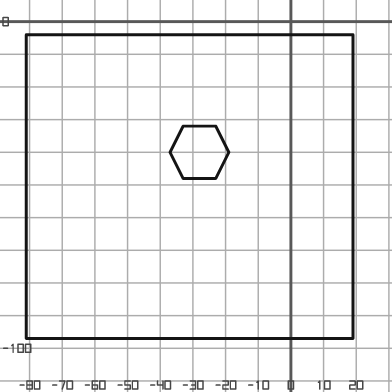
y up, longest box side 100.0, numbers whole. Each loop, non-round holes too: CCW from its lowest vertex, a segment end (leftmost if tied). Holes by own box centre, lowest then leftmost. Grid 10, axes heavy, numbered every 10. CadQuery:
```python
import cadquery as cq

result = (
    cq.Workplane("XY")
    .moveTo(-81.0, -97.0)
    .lineTo(19.0, -97.0)
    .lineTo(19.0, -4.0)
    .lineTo(-81.0, -4.0)
    .close()
    .moveTo(-33.0, -48.0)
    .lineTo(-23.0, -48.0)
    .lineTo(-19.0, -40.0)
    .lineTo(-23.0, -32.0)
    .lineTo(-33.0, -32.0)
    .lineTo(-37.0, -40.0)
    .close()
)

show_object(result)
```